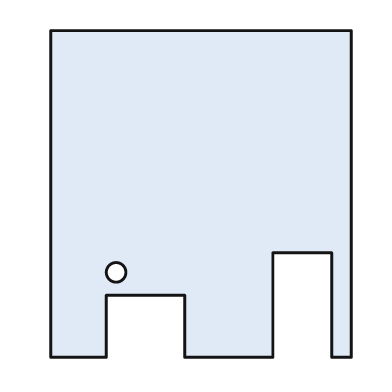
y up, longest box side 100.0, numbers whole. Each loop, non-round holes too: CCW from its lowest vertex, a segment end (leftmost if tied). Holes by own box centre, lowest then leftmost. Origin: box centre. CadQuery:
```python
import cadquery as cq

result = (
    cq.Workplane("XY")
    .moveTo(-46.0, -50.0)
    .lineTo(-29.0, -50.0)
    .lineTo(-29.0, -31.0)
    .lineTo(-5.0, -31.0)
    .lineTo(-5.0, -50.0)
    .lineTo(22.0, -50.0)
    .lineTo(22.0, -18.0)
    .lineTo(40.0, -18.0)
    .lineTo(40.0, -50.0)
    .lineTo(46.0, -50.0)
    .lineTo(46.0, 50.0)
    .lineTo(-46.0, 50.0)
    .close()
    .moveTo(-26.0, -24.0)
    .circle(3.0)
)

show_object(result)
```